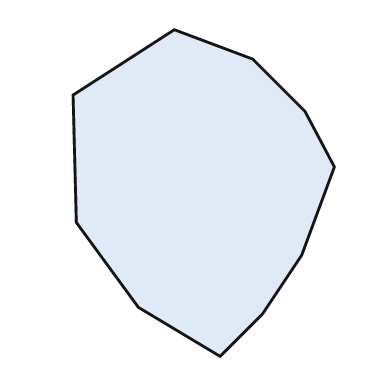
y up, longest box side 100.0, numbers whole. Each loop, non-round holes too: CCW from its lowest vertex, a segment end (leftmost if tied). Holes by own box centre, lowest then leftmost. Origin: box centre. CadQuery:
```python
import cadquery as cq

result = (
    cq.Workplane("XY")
    .moveTo(5.0, -50.0)
    .lineTo(18.0, -37.0)
    .lineTo(30.0, -19.0)
    .lineTo(40.0, 8.0)
    .lineTo(31.0, 25.0)
    .lineTo(15.0, 41.0)
    .lineTo(-9.0, 50.0)
    .lineTo(-40.0, 30.0)
    .lineTo(-39.0, -9.0)
    .lineTo(-20.0, -35.0)
    .close()
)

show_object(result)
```